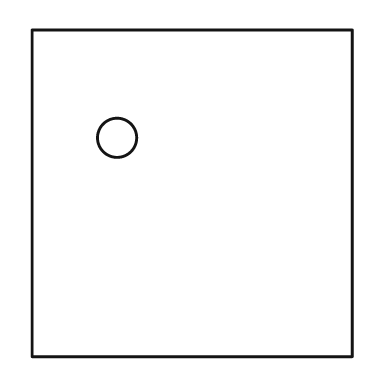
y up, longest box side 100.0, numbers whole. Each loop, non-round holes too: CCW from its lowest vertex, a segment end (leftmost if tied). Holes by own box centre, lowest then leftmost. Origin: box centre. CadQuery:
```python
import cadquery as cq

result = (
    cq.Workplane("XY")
    .moveTo(-49.0, -50.0)
    .lineTo(49.0, -50.0)
    .lineTo(49.0, 50.0)
    .lineTo(-49.0, 50.0)
    .close()
    .moveTo(-23.0, 17.0)
    .circle(6.0)
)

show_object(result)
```